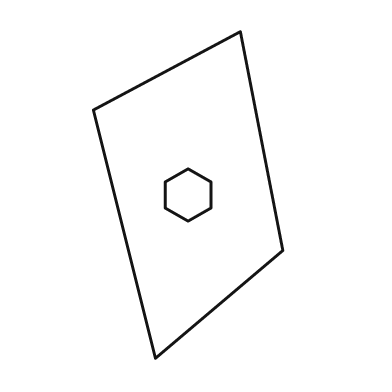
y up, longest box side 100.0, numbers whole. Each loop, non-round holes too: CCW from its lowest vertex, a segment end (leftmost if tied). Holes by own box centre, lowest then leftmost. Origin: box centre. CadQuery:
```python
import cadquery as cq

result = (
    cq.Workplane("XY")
    .moveTo(-10.0, -50.0)
    .lineTo(29.0, -17.0)
    .lineTo(16.0, 50.0)
    .lineTo(-29.0, 26.0)
    .close()
    .moveTo(0.0, -8.0)
    .lineTo(7.0, -4.0)
    .lineTo(7.0, 4.0)
    .lineTo(0.0, 8.0)
    .lineTo(-7.0, 4.0)
    .lineTo(-7.0, -4.0)
    .close()
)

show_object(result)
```